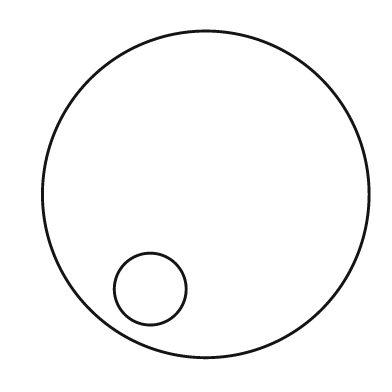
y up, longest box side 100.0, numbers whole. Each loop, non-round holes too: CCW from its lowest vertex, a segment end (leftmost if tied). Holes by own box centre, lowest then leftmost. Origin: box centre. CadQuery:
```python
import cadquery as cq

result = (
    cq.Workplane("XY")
    .moveTo(0.0, 0.0)
    .circle(50.0)
    .moveTo(-17.0, -29.0)
    .circle(11.0)
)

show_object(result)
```